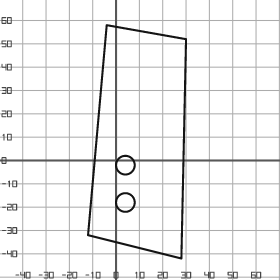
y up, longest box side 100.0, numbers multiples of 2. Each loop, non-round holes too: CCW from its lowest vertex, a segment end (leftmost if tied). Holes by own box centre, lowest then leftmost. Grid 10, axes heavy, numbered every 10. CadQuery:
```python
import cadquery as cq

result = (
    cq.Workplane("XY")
    .moveTo(28.0, -42.0)
    .lineTo(30.0, 52.0)
    .lineTo(-4.0, 58.0)
    .lineTo(-12.0, -32.0)
    .close()
    .moveTo(4.0, -18.0)
    .circle(4.0)
    .moveTo(4.0, -2.0)
    .circle(4.0)
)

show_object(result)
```